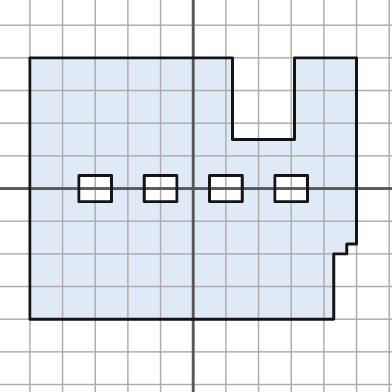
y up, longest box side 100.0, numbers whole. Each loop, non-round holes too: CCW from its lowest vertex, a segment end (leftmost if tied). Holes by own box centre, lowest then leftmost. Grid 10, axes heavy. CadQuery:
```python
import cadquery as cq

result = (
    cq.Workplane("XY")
    .moveTo(-50.0, -40.0)
    .lineTo(43.0, -40.0)
    .lineTo(43.0, -20.0)
    .lineTo(47.0, -20.0)
    .lineTo(47.0, -17.0)
    .lineTo(50.0, -17.0)
    .lineTo(50.0, 40.0)
    .lineTo(31.0, 40.0)
    .lineTo(31.0, 15.0)
    .lineTo(12.0, 15.0)
    .lineTo(12.0, 40.0)
    .lineTo(-50.0, 40.0)
    .close()
    .moveTo(-35.0, -4.0)
    .lineTo(-25.0, -4.0)
    .lineTo(-25.0, 4.0)
    .lineTo(-35.0, 4.0)
    .close()
    .moveTo(-15.0, -4.0)
    .lineTo(-5.0, -4.0)
    .lineTo(-5.0, 4.0)
    .lineTo(-15.0, 4.0)
    .close()
    .moveTo(5.0, -4.0)
    .lineTo(15.0, -4.0)
    .lineTo(15.0, 4.0)
    .lineTo(5.0, 4.0)
    .close()
    .moveTo(25.0, -4.0)
    .lineTo(35.0, -4.0)
    .lineTo(35.0, 4.0)
    .lineTo(25.0, 4.0)
    .close()
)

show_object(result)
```